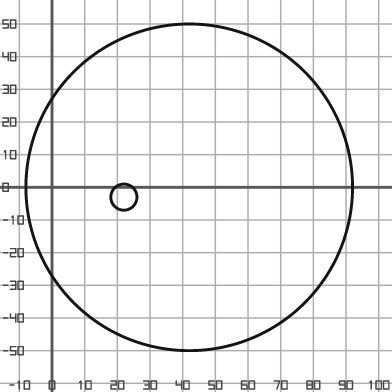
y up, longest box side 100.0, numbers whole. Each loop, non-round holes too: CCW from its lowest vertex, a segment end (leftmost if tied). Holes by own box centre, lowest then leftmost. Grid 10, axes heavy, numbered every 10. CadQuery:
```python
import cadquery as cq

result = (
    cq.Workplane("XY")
    .moveTo(42.0, 0.0)
    .circle(50.0)
    .moveTo(22.0, -3.0)
    .circle(4.0)
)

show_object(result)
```